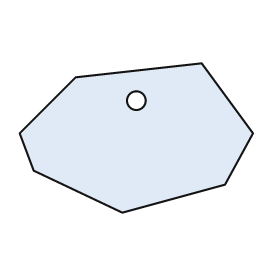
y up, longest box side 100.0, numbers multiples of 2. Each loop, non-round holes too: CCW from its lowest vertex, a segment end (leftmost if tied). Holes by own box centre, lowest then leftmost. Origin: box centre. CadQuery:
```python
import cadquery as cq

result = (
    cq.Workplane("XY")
    .moveTo(-6.0, -32.0)
    .lineTo(38.0, -20.0)
    .lineTo(50.0, 2.0)
    .lineTo(28.0, 32.0)
    .lineTo(-26.0, 26.0)
    .lineTo(-50.0, 2.0)
    .lineTo(-44.0, -14.0)
    .close()
    .moveTo(0.0, 16.0)
    .circle(4.0)
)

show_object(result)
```